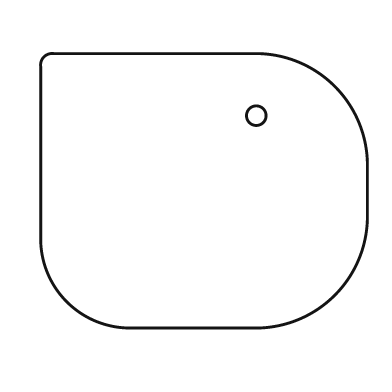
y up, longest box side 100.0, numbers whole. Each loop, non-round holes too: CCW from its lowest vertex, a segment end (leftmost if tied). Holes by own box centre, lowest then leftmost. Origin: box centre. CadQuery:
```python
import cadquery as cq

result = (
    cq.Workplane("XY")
    .moveTo(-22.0, -42.0)
    .lineTo(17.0, -42.0)
    .threePointArc((40.0, -32.0), (50.0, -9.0))
    .lineTo(50.0, 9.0)
    .threePointArc((40.0, 32.0), (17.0, 42.0))
    .lineTo(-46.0, 42.0)
    .threePointArc((-49.0, 41.0), (-50.0, 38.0))
    .lineTo(-50.0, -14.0)
    .threePointArc((-42.0, -34.0), (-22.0, -42.0))
    .close()
    .moveTo(16.0, 23.0)
    .circle(3.0)
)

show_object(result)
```